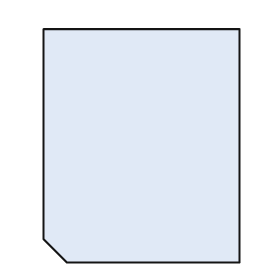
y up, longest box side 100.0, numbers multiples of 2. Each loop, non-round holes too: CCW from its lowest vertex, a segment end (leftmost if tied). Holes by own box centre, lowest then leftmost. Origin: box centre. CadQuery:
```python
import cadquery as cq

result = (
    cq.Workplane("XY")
    .moveTo(-32.0, -50.0)
    .lineTo(42.0, -50.0)
    .lineTo(42.0, 50.0)
    .lineTo(-42.0, 50.0)
    .lineTo(-42.0, -40.0)
    .close()
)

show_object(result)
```